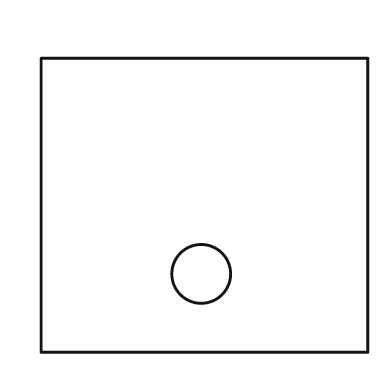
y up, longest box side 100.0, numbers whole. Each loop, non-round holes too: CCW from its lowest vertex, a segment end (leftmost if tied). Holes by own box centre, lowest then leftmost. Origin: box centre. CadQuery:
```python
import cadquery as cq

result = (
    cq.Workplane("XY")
    .moveTo(-50.0, -45.0)
    .lineTo(50.0, -45.0)
    .lineTo(50.0, 45.0)
    .lineTo(-50.0, 45.0)
    .close()
    .moveTo(-1.0, -21.0)
    .circle(9.0)
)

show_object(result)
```